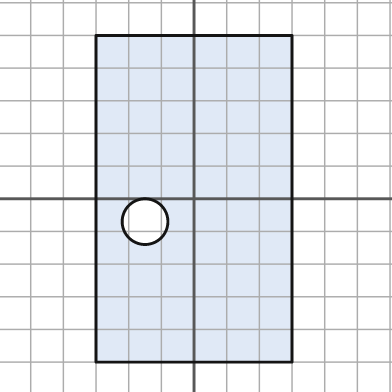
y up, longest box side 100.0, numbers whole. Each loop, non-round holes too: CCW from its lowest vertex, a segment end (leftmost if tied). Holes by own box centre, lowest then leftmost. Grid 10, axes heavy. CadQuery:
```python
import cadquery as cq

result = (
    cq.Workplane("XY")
    .moveTo(-30.0, -50.0)
    .lineTo(30.0, -50.0)
    .lineTo(30.0, 50.0)
    .lineTo(-30.0, 50.0)
    .close()
    .moveTo(-15.0, -7.0)
    .circle(7.0)
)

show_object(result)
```